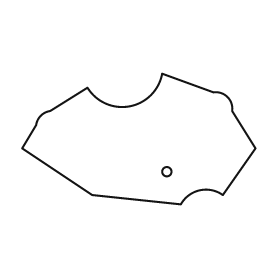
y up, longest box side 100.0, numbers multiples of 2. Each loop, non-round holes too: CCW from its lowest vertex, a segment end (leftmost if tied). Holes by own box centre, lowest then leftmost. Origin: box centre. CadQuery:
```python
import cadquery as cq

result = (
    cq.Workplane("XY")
    .moveTo(18.0, -28.0)
    .threePointArc((26.0, -22.0), (36.0, -24.0))
    .lineTo(50.0, -4.0)
    .lineTo(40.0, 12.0)
    .threePointArc((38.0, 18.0), (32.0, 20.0))
    .lineTo(10.0, 28.0)
    .threePointArc((-4.0, 14.0), (-22.0, 22.0))
    .lineTo(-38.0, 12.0)
    .threePointArc((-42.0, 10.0), (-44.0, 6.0))
    .lineTo(-50.0, -4.0)
    .lineTo(-20.0, -24.0)
    .close()
    .moveTo(12.0, -14.0)
    .circle(2.0)
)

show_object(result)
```